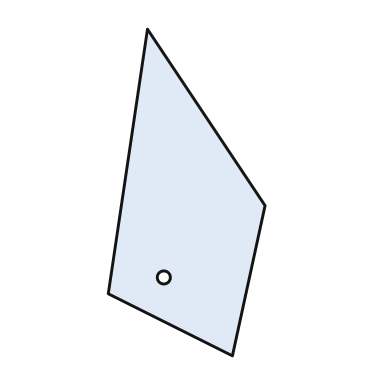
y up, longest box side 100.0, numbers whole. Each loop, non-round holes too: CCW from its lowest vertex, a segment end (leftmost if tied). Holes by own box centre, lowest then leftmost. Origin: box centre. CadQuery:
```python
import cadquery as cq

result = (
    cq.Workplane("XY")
    .moveTo(14.0, -50.0)
    .lineTo(24.0, -4.0)
    .lineTo(-12.0, 50.0)
    .lineTo(-24.0, -31.0)
    .close()
    .moveTo(-7.0, -26.0)
    .circle(2.0)
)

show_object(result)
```